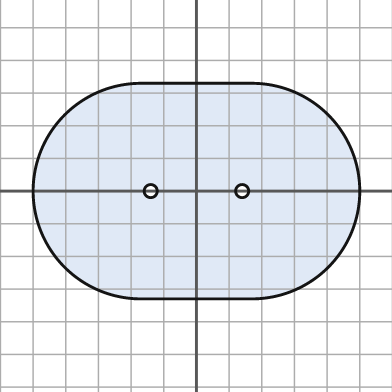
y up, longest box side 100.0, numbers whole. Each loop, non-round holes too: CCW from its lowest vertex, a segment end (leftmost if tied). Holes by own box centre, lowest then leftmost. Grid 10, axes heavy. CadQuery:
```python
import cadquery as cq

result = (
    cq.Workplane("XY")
    .moveTo(-17.0, -33.0)
    .lineTo(17.0, -33.0)
    .threePointArc((50.0, 0.0), (17.0, 33.0))
    .lineTo(-17.0, 33.0)
    .threePointArc((-50.0, 0.0), (-17.0, -33.0))
    .close()
    .moveTo(-14.0, 0.0)
    .circle(2.0)
    .moveTo(14.0, 0.0)
    .circle(2.0)
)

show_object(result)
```